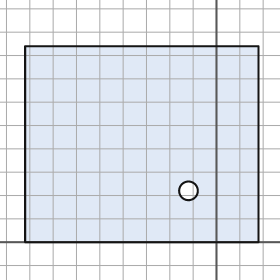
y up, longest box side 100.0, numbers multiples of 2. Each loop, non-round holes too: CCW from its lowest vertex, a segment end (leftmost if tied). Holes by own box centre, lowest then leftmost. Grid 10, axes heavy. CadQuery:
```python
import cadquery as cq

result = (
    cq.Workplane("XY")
    .moveTo(-82.0, 0.0)
    .lineTo(18.0, 0.0)
    .lineTo(18.0, 84.0)
    .lineTo(-82.0, 84.0)
    .close()
    .moveTo(-12.0, 22.0)
    .circle(4.0)
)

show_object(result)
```